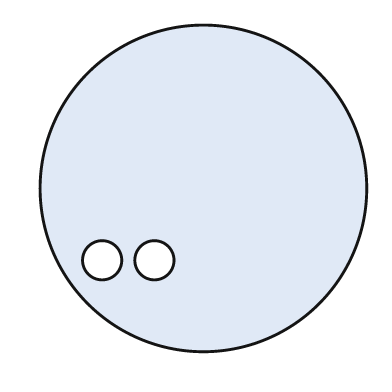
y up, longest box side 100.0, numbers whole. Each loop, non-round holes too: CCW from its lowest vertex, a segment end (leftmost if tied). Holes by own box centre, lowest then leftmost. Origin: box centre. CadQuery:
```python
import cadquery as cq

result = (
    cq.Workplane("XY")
    .moveTo(0.0, 0.0)
    .circle(50.0)
    .moveTo(-31.0, -22.0)
    .circle(6.0)
    .moveTo(-15.0, -22.0)
    .circle(6.0)
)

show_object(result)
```